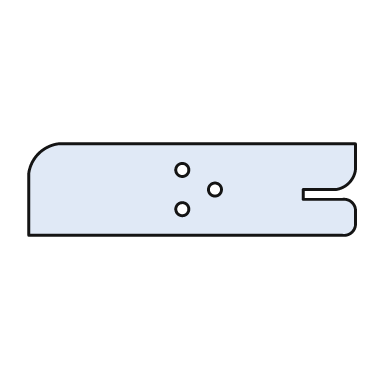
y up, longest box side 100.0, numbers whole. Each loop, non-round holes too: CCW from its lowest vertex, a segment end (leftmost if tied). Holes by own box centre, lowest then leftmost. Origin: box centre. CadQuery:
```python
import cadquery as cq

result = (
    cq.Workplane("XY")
    .moveTo(-50.0, -14.0)
    .lineTo(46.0, -14.0)
    .threePointArc((49.0, -13.0), (50.0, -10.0))
    .lineTo(50.0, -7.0)
    .threePointArc((49.0, -4.0), (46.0, -3.0))
    .lineTo(34.0, -3.0)
    .lineTo(34.0, 0.0)
    .lineTo(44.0, 0.0)
    .threePointArc((48.0, 2.0), (50.0, 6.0))
    .lineTo(50.0, 14.0)
    .lineTo(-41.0, 14.0)
    .threePointArc((-47.0, 11.0), (-50.0, 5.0))
    .close()
    .moveTo(-3.0, -6.0)
    .circle(2.0)
    .moveTo(7.0, 0.0)
    .circle(2.0)
    .moveTo(-3.0, 6.0)
    .circle(2.0)
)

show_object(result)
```